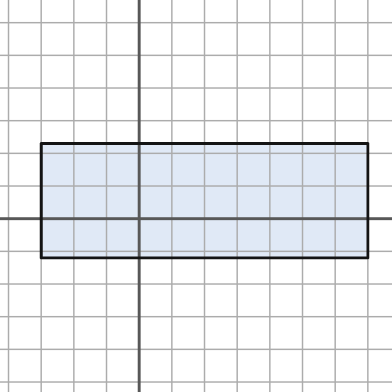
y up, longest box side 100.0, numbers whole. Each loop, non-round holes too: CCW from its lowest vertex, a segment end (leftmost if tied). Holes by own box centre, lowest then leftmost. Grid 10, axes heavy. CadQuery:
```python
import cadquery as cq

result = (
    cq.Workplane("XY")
    .moveTo(-30.0, -12.0)
    .lineTo(70.0, -12.0)
    .lineTo(70.0, 23.0)
    .lineTo(-30.0, 23.0)
    .close()
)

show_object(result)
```